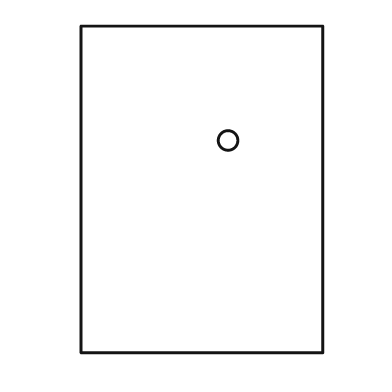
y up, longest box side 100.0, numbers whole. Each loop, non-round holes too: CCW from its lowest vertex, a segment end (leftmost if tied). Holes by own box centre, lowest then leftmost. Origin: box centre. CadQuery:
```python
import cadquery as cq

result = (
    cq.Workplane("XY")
    .moveTo(-37.0, -50.0)
    .lineTo(37.0, -50.0)
    .lineTo(37.0, 50.0)
    .lineTo(-37.0, 50.0)
    .close()
    .moveTo(8.0, 15.0)
    .circle(3.0)
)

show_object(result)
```